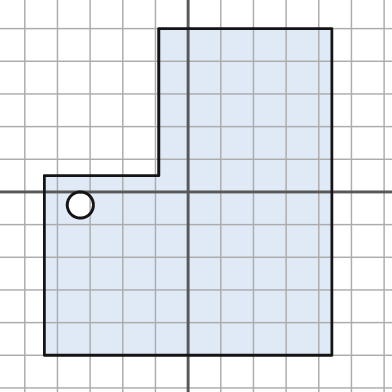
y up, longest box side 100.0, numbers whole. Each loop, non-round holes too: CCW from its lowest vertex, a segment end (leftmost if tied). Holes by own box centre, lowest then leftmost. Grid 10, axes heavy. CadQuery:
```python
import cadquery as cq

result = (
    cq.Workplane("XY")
    .moveTo(-44.0, -50.0)
    .lineTo(44.0, -50.0)
    .lineTo(44.0, 50.0)
    .lineTo(-9.0, 50.0)
    .lineTo(-9.0, 5.0)
    .lineTo(-44.0, 5.0)
    .close()
    .moveTo(-33.0, -4.0)
    .circle(4.0)
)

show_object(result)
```